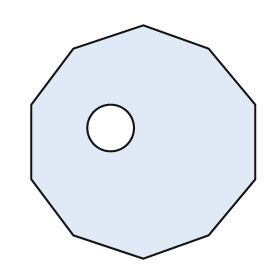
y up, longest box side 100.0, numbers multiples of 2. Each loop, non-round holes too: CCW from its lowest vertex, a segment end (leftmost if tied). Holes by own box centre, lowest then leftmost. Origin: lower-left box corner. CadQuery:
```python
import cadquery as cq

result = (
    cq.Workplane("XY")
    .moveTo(48.0, 0.0)
    .lineTo(76.0, 10.0)
    .lineTo(96.0, 34.0)
    .lineTo(96.0, 66.0)
    .lineTo(76.0, 90.0)
    .lineTo(48.0, 100.0)
    .lineTo(18.0, 90.0)
    .lineTo(0.0, 66.0)
    .lineTo(0.0, 34.0)
    .lineTo(18.0, 10.0)
    .close()
    .moveTo(34.0, 56.0)
    .circle(10.0)
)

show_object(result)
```